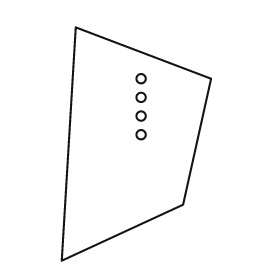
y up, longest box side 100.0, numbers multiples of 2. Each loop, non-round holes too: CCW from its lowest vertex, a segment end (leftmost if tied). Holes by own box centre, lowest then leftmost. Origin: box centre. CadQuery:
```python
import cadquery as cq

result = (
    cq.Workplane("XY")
    .moveTo(-32.0, -50.0)
    .lineTo(20.0, -26.0)
    .lineTo(32.0, 28.0)
    .lineTo(-26.0, 50.0)
    .close()
    .moveTo(2.0, 4.0)
    .circle(2.0)
    .moveTo(2.0, 12.0)
    .circle(2.0)
    .moveTo(2.0, 20.0)
    .circle(2.0)
    .moveTo(2.0, 28.0)
    .circle(2.0)
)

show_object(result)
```